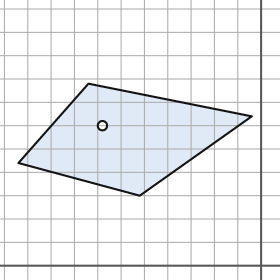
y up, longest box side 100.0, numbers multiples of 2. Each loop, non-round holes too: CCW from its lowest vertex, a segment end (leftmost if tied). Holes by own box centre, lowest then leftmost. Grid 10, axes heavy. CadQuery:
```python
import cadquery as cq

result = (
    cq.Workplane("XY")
    .moveTo(-52.0, 30.0)
    .lineTo(-4.0, 64.0)
    .lineTo(-74.0, 78.0)
    .lineTo(-104.0, 44.0)
    .close()
    .moveTo(-68.0, 60.0)
    .circle(2.0)
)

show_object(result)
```